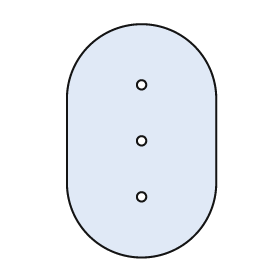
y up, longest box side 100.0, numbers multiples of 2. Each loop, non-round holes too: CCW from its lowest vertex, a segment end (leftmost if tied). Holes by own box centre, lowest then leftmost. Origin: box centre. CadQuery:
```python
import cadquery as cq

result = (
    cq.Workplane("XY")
    .moveTo(-32.0, -18.0)
    .threePointArc((0.0, -50.0), (32.0, -18.0))
    .lineTo(32.0, 18.0)
    .threePointArc((0.0, 50.0), (-32.0, 18.0))
    .close()
    .moveTo(0.0, -24.0)
    .circle(2.0)
    .moveTo(0.0, 0.0)
    .circle(2.0)
    .moveTo(0.0, 24.0)
    .circle(2.0)
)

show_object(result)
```